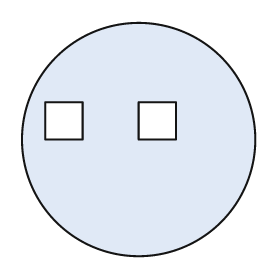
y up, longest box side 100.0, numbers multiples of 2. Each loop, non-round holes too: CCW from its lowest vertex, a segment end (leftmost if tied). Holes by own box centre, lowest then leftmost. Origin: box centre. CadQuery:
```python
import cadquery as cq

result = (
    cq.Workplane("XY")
    .moveTo(0.0, 0.0)
    .circle(50.0)
    .moveTo(-40.0, 0.0)
    .lineTo(-24.0, 0.0)
    .lineTo(-24.0, 16.0)
    .lineTo(-40.0, 16.0)
    .close()
    .moveTo(0.0, 0.0)
    .lineTo(16.0, 0.0)
    .lineTo(16.0, 16.0)
    .lineTo(0.0, 16.0)
    .close()
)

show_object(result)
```